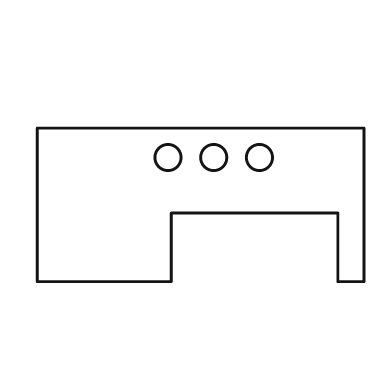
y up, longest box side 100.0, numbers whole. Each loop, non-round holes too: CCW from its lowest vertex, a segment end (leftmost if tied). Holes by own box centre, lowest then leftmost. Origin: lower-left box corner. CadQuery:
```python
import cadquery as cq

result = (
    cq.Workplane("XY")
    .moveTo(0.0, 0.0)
    .lineTo(41.0, 0.0)
    .lineTo(41.0, 21.0)
    .lineTo(92.0, 21.0)
    .lineTo(92.0, 0.0)
    .lineTo(100.0, 0.0)
    .lineTo(100.0, 47.0)
    .lineTo(0.0, 47.0)
    .close()
    .moveTo(40.0, 38.0)
    .circle(4.0)
    .moveTo(54.0, 38.0)
    .circle(4.0)
    .moveTo(68.0, 38.0)
    .circle(4.0)
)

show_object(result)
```